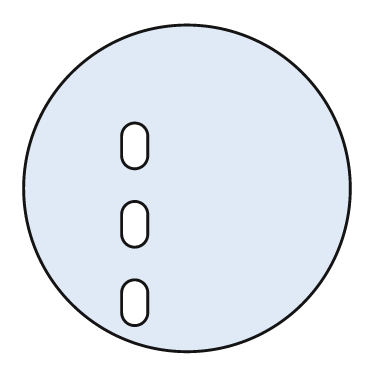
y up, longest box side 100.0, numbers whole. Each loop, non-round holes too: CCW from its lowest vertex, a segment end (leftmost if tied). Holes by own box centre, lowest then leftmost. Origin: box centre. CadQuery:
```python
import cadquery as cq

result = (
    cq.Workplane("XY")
    .moveTo(0.0, 0.0)
    .circle(50.0)
    .moveTo(-20.0, -38.0)
    .threePointArc((-16.0, -42.0), (-12.0, -38.0))
    .lineTo(-12.0, -32.0)
    .threePointArc((-16.0, -28.0), (-20.0, -32.0))
    .close()
    .moveTo(-20.0, -14.0)
    .threePointArc((-16.0, -18.0), (-12.0, -14.0))
    .lineTo(-12.0, -8.0)
    .threePointArc((-16.0, -4.0), (-20.0, -8.0))
    .close()
    .moveTo(-20.0, 10.0)
    .threePointArc((-16.0, 6.0), (-12.0, 10.0))
    .lineTo(-12.0, 16.0)
    .threePointArc((-16.0, 20.0), (-20.0, 16.0))
    .close()
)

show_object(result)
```